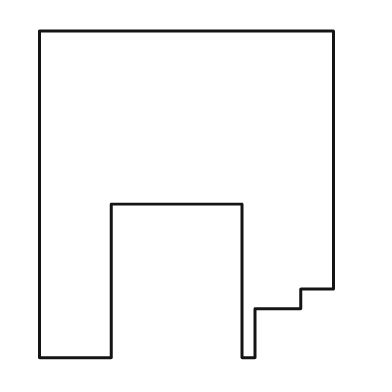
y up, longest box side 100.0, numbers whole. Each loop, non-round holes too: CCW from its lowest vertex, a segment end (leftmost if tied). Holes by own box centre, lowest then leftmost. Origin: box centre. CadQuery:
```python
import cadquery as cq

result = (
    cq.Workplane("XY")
    .moveTo(-45.0, -50.0)
    .lineTo(-23.0, -50.0)
    .lineTo(-23.0, -3.0)
    .lineTo(17.0, -3.0)
    .lineTo(17.0, -50.0)
    .lineTo(21.0, -50.0)
    .lineTo(21.0, -35.0)
    .lineTo(35.0, -35.0)
    .lineTo(35.0, -29.0)
    .lineTo(45.0, -29.0)
    .lineTo(45.0, 50.0)
    .lineTo(-45.0, 50.0)
    .close()
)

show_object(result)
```